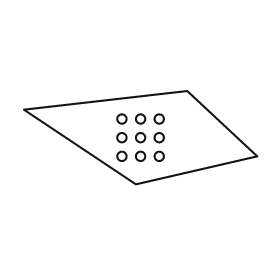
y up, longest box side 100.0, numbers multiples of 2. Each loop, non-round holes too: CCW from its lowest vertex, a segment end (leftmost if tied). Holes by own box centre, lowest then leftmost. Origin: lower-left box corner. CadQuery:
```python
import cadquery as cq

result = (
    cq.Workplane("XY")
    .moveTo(48.0, 0.0)
    .lineTo(100.0, 12.0)
    .lineTo(70.0, 40.0)
    .lineTo(0.0, 32.0)
    .close()
    .moveTo(42.0, 12.0)
    .circle(2.0)
    .moveTo(50.0, 12.0)
    .circle(2.0)
    .moveTo(58.0, 12.0)
    .circle(2.0)
    .moveTo(42.0, 20.0)
    .circle(2.0)
    .moveTo(50.0, 20.0)
    .circle(2.0)
    .moveTo(58.0, 20.0)
    .circle(2.0)
    .moveTo(42.0, 28.0)
    .circle(2.0)
    .moveTo(50.0, 28.0)
    .circle(2.0)
    .moveTo(58.0, 28.0)
    .circle(2.0)
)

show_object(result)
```